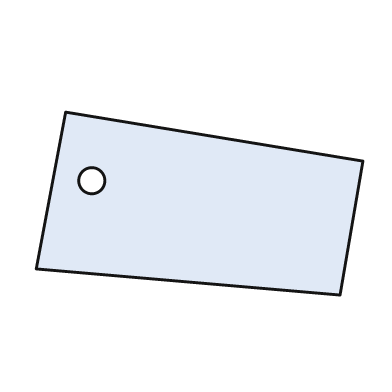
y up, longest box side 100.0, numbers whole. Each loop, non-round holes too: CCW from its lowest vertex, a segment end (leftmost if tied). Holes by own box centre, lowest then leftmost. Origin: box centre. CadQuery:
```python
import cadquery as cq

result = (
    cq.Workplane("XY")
    .moveTo(43.0, -28.0)
    .lineTo(50.0, 13.0)
    .lineTo(-41.0, 28.0)
    .lineTo(-50.0, -20.0)
    .close()
    .moveTo(-33.0, 7.0)
    .circle(4.0)
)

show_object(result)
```